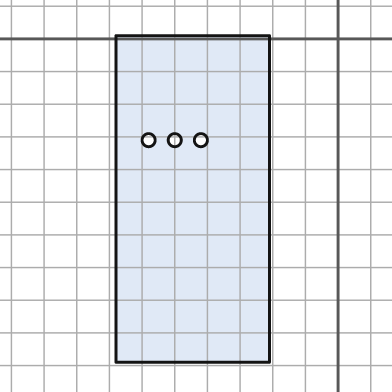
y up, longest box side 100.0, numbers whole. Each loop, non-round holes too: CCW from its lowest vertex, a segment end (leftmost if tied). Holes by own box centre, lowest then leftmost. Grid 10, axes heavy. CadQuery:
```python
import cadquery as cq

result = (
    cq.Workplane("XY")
    .moveTo(-68.0, -99.0)
    .lineTo(-21.0, -99.0)
    .lineTo(-21.0, 1.0)
    .lineTo(-68.0, 1.0)
    .close()
    .moveTo(-58.0, -31.0)
    .circle(2.0)
    .moveTo(-50.0, -31.0)
    .circle(2.0)
    .moveTo(-42.0, -31.0)
    .circle(2.0)
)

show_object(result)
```